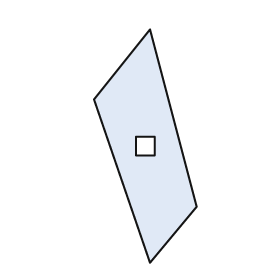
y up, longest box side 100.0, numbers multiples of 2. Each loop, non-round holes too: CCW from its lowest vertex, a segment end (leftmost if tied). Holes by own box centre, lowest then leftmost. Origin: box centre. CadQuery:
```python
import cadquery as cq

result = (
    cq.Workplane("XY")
    .moveTo(2.0, -50.0)
    .lineTo(22.0, -26.0)
    .lineTo(2.0, 50.0)
    .lineTo(-22.0, 20.0)
    .close()
    .moveTo(-4.0, -4.0)
    .lineTo(4.0, -4.0)
    .lineTo(4.0, 4.0)
    .lineTo(-4.0, 4.0)
    .close()
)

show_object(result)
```